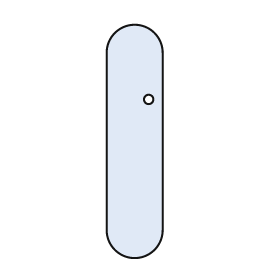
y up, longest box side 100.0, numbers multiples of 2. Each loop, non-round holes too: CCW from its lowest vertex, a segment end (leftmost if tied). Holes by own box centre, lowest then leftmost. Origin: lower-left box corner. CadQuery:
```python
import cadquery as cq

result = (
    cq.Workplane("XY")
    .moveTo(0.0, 12.0)
    .threePointArc((12.0, 0.0), (24.0, 12.0))
    .lineTo(24.0, 88.0)
    .threePointArc((12.0, 100.0), (0.0, 88.0))
    .close()
    .moveTo(18.0, 68.0)
    .circle(2.0)
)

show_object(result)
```